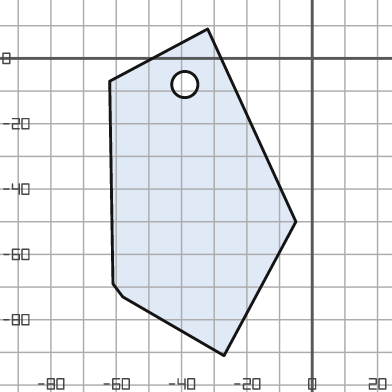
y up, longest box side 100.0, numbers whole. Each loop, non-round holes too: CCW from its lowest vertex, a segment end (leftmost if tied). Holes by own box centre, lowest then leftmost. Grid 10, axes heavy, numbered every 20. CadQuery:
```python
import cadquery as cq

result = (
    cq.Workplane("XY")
    .moveTo(-27.0, -91.0)
    .lineTo(-5.0, -50.0)
    .lineTo(-32.0, 9.0)
    .lineTo(-62.0, -7.0)
    .lineTo(-61.0, -69.0)
    .lineTo(-58.0, -73.0)
    .close()
    .moveTo(-39.0, -8.0)
    .circle(4.0)
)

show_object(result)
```